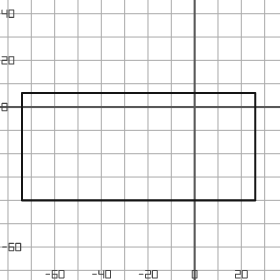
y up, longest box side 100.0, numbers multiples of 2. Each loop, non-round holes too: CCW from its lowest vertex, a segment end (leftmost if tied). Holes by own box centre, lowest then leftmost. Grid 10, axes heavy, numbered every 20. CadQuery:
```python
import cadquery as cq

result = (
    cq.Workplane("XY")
    .moveTo(-74.0, -40.0)
    .lineTo(26.0, -40.0)
    .lineTo(26.0, 6.0)
    .lineTo(-74.0, 6.0)
    .close()
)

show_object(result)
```